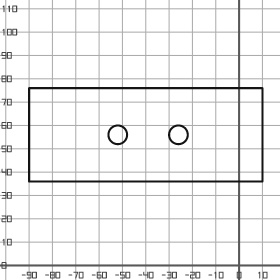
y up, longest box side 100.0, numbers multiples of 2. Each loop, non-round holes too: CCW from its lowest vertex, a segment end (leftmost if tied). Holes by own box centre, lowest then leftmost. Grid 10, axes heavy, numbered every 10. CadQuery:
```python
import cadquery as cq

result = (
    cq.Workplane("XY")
    .moveTo(-90.0, 36.0)
    .lineTo(10.0, 36.0)
    .lineTo(10.0, 76.0)
    .lineTo(-90.0, 76.0)
    .close()
    .moveTo(-52.0, 56.0)
    .circle(4.0)
    .moveTo(-26.0, 56.0)
    .circle(4.0)
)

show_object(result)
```